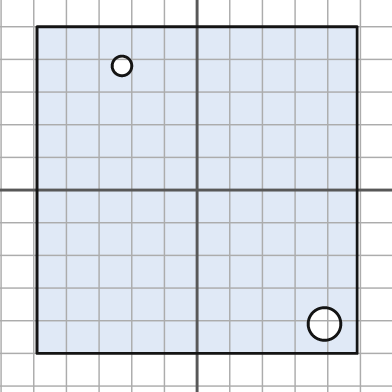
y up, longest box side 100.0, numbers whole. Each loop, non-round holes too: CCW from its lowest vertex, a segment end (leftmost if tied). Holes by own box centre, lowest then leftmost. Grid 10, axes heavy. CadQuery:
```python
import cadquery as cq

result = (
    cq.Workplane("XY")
    .moveTo(-49.0, -50.0)
    .lineTo(49.0, -50.0)
    .lineTo(49.0, 50.0)
    .lineTo(-49.0, 50.0)
    .close()
    .moveTo(39.0, -41.0)
    .circle(5.0)
    .moveTo(-23.0, 38.0)
    .circle(3.0)
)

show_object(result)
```